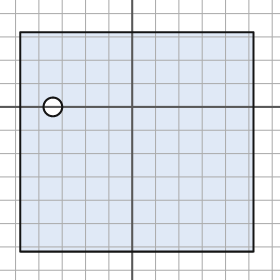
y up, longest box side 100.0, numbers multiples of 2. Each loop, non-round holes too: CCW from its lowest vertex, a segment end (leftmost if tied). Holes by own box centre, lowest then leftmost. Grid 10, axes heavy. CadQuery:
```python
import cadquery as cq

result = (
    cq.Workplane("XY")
    .moveTo(-48.0, -62.0)
    .lineTo(52.0, -62.0)
    .lineTo(52.0, 32.0)
    .lineTo(-48.0, 32.0)
    .close()
    .moveTo(-34.0, 0.0)
    .circle(4.0)
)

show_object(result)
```